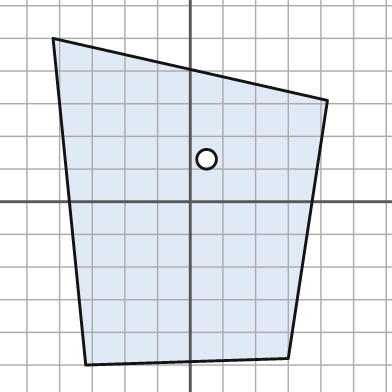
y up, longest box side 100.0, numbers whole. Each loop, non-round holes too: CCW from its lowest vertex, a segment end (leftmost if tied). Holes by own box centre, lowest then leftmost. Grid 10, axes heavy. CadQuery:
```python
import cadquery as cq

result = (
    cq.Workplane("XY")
    .moveTo(-32.0, -50.0)
    .lineTo(30.0, -48.0)
    .lineTo(42.0, 31.0)
    .lineTo(-42.0, 50.0)
    .close()
    .moveTo(5.0, 13.0)
    .circle(3.0)
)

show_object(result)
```